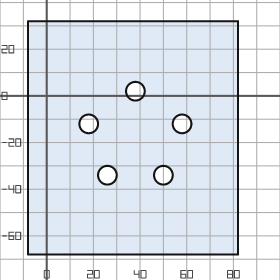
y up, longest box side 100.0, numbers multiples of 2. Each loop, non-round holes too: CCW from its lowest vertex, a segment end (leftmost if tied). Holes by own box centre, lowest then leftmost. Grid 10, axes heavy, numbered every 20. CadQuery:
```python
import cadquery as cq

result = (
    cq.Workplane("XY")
    .moveTo(-8.0, -68.0)
    .lineTo(82.0, -68.0)
    .lineTo(82.0, 32.0)
    .lineTo(-8.0, 32.0)
    .close()
    .moveTo(26.0, -34.0)
    .circle(4.0)
    .moveTo(50.0, -34.0)
    .circle(4.0)
    .moveTo(18.0, -12.0)
    .circle(4.0)
    .moveTo(58.0, -12.0)
    .circle(4.0)
    .moveTo(38.0, 2.0)
    .circle(4.0)
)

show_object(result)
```